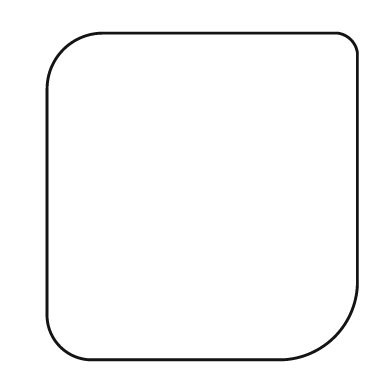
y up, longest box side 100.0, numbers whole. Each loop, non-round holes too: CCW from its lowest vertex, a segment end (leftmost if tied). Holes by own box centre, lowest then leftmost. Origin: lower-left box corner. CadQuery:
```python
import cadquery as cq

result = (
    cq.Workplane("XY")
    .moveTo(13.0, 0.0)
    .lineTo(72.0, 0.0)
    .threePointArc((88.0, 7.0), (95.0, 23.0))
    .lineTo(95.0, 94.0)
    .threePointArc((93.0, 98.0), (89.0, 100.0))
    .lineTo(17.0, 100.0)
    .threePointArc((5.0, 95.0), (0.0, 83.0))
    .lineTo(0.0, 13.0)
    .threePointArc((4.0, 4.0), (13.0, 0.0))
    .close()
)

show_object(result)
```